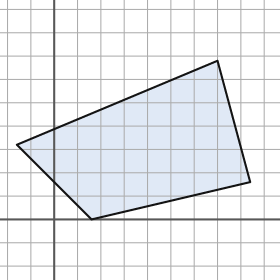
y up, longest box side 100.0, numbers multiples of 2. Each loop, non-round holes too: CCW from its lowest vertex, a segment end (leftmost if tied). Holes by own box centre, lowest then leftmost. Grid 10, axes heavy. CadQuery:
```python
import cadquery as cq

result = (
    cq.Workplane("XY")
    .moveTo(16.0, 0.0)
    .lineTo(84.0, 16.0)
    .lineTo(70.0, 68.0)
    .lineTo(-16.0, 32.0)
    .close()
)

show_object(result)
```